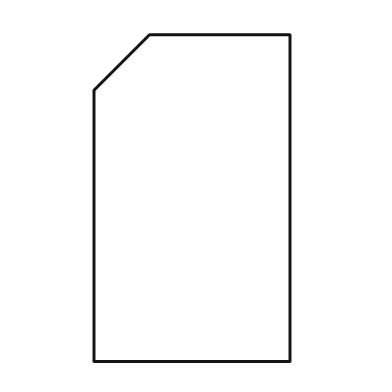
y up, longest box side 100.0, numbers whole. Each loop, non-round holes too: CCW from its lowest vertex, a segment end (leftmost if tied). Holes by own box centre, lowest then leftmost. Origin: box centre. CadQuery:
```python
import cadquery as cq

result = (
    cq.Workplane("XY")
    .moveTo(-30.0, -50.0)
    .lineTo(30.0, -50.0)
    .lineTo(30.0, 50.0)
    .lineTo(-13.0, 50.0)
    .lineTo(-30.0, 33.0)
    .close()
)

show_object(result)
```